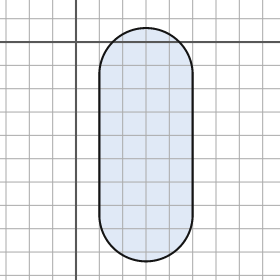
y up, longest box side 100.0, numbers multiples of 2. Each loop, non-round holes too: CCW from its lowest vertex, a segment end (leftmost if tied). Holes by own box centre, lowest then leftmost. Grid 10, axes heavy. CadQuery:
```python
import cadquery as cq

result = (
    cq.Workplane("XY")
    .moveTo(10.0, -74.0)
    .threePointArc((30.0, -94.0), (50.0, -74.0))
    .lineTo(50.0, -14.0)
    .threePointArc((30.0, 6.0), (10.0, -14.0))
    .close()
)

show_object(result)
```